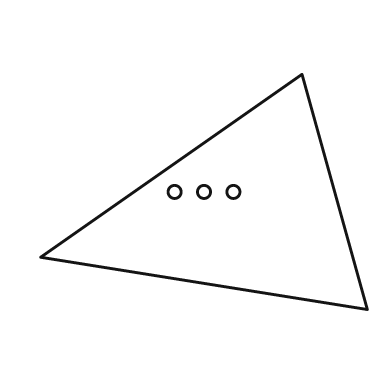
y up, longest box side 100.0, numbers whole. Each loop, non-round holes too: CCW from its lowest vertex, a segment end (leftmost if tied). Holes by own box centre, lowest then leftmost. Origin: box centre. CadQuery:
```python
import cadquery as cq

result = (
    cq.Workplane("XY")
    .moveTo(50.0, -36.0)
    .lineTo(30.0, 36.0)
    .lineTo(-50.0, -20.0)
    .close()
    .moveTo(-9.0, 0.0)
    .circle(2.0)
    .moveTo(0.0, 0.0)
    .circle(2.0)
    .moveTo(9.0, 0.0)
    .circle(2.0)
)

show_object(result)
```